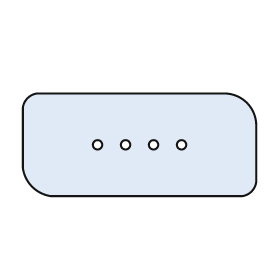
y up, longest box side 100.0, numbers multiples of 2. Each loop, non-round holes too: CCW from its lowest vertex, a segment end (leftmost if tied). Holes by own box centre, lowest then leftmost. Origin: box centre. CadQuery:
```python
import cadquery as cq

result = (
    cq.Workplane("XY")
    .moveTo(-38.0, -22.0)
    .lineTo(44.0, -22.0)
    .threePointArc((48.0, -20.0), (50.0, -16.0))
    .lineTo(50.0, 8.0)
    .threePointArc((46.0, 18.0), (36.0, 22.0))
    .lineTo(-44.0, 22.0)
    .threePointArc((-48.0, 20.0), (-50.0, 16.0))
    .lineTo(-50.0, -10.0)
    .threePointArc((-46.0, -18.0), (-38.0, -22.0))
    .close()
    .moveTo(-18.0, 0.0)
    .circle(2.0)
    .moveTo(-6.0, 0.0)
    .circle(2.0)
    .moveTo(6.0, 0.0)
    .circle(2.0)
    .moveTo(18.0, 0.0)
    .circle(2.0)
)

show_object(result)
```